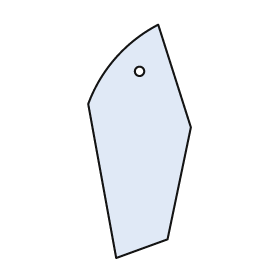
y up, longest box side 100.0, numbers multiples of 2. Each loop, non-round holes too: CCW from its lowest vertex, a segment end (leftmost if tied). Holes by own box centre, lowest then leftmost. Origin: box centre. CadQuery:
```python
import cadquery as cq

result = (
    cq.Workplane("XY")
    .moveTo(-10.0, -50.0)
    .lineTo(12.0, -42.0)
    .lineTo(22.0, 6.0)
    .lineTo(8.0, 50.0)
    .threePointArc((-10.0, 36.0), (-22.0, 16.0))
    .close()
    .moveTo(0.0, 30.0)
    .circle(2.0)
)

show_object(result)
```